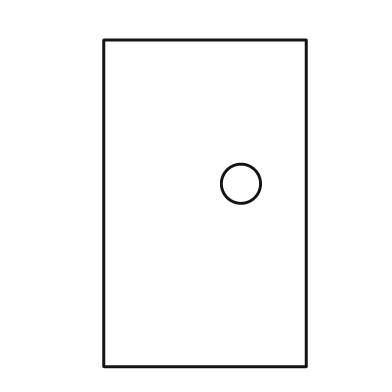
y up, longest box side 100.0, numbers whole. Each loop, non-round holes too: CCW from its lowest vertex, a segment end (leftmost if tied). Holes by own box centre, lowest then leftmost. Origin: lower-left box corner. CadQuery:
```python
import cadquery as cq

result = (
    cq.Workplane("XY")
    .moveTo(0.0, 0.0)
    .lineTo(62.0, 0.0)
    .lineTo(62.0, 100.0)
    .lineTo(0.0, 100.0)
    .close()
    .moveTo(42.0, 56.0)
    .circle(6.0)
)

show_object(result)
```